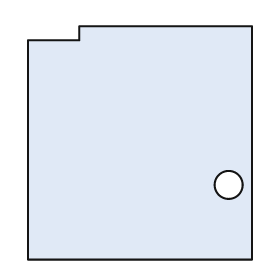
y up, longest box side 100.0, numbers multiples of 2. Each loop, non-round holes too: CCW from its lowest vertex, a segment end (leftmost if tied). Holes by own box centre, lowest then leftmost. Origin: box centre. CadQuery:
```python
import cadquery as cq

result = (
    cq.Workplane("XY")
    .moveTo(-48.0, -50.0)
    .lineTo(48.0, -50.0)
    .lineTo(48.0, 50.0)
    .lineTo(-26.0, 50.0)
    .lineTo(-26.0, 44.0)
    .lineTo(-48.0, 44.0)
    .close()
    .moveTo(38.0, -18.0)
    .circle(6.0)
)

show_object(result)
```